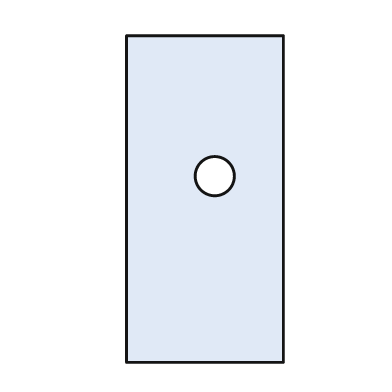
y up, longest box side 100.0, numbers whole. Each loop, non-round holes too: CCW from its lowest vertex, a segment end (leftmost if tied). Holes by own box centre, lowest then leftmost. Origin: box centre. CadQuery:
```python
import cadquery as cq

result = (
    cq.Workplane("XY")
    .moveTo(-24.0, -50.0)
    .lineTo(24.0, -50.0)
    .lineTo(24.0, 50.0)
    .lineTo(-24.0, 50.0)
    .close()
    .moveTo(3.0, 7.0)
    .circle(6.0)
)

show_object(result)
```